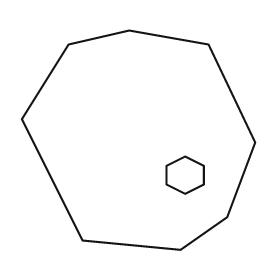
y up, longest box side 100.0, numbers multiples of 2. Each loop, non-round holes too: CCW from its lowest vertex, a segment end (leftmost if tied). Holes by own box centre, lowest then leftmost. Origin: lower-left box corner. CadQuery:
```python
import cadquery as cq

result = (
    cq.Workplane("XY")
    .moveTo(68.0, 0.0)
    .lineTo(88.0, 14.0)
    .lineTo(100.0, 46.0)
    .lineTo(80.0, 88.0)
    .lineTo(46.0, 94.0)
    .lineTo(20.0, 88.0)
    .lineTo(0.0, 56.0)
    .lineTo(26.0, 4.0)
    .close()
    .moveTo(70.0, 24.0)
    .lineTo(78.0, 28.0)
    .lineTo(78.0, 36.0)
    .lineTo(70.0, 40.0)
    .lineTo(62.0, 36.0)
    .lineTo(62.0, 28.0)
    .close()
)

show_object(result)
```